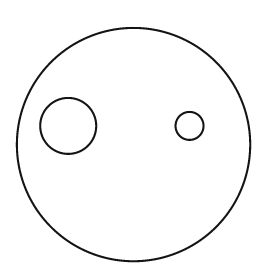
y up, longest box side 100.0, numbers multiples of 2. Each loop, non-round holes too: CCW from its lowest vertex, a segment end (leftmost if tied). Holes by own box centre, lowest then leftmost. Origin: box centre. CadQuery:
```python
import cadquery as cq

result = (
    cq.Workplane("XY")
    .moveTo(0.0, 0.0)
    .circle(50.0)
    .moveTo(-28.0, 8.0)
    .circle(12.0)
    .moveTo(24.0, 8.0)
    .circle(6.0)
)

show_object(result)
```